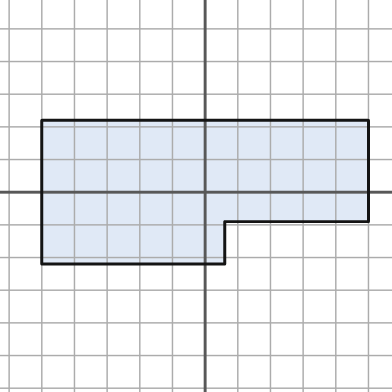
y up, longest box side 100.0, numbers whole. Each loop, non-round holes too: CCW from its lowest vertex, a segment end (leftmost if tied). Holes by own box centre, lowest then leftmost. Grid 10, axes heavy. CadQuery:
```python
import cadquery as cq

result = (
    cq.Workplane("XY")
    .moveTo(-50.0, -22.0)
    .lineTo(6.0, -22.0)
    .lineTo(6.0, -9.0)
    .lineTo(50.0, -9.0)
    .lineTo(50.0, 22.0)
    .lineTo(-50.0, 22.0)
    .close()
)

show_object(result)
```